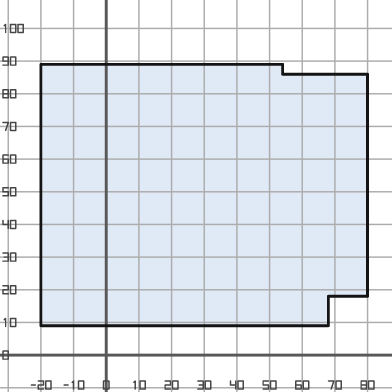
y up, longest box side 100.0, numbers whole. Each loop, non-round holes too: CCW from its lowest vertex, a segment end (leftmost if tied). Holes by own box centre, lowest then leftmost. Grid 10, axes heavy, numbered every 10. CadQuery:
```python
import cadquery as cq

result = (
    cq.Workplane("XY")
    .moveTo(-20.0, 9.0)
    .lineTo(68.0, 9.0)
    .lineTo(68.0, 18.0)
    .lineTo(80.0, 18.0)
    .lineTo(80.0, 86.0)
    .lineTo(54.0, 86.0)
    .lineTo(54.0, 89.0)
    .lineTo(-20.0, 89.0)
    .close()
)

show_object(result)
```